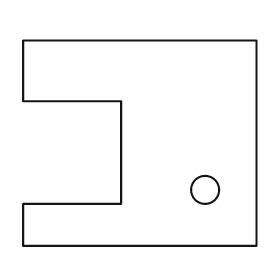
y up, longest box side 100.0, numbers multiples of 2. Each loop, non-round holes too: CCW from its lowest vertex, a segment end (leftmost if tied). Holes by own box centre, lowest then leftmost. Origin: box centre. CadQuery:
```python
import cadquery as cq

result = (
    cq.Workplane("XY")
    .moveTo(-50.0, -44.0)
    .lineTo(50.0, -44.0)
    .lineTo(50.0, 44.0)
    .lineTo(-50.0, 44.0)
    .lineTo(-50.0, 18.0)
    .lineTo(-8.0, 18.0)
    .lineTo(-8.0, -26.0)
    .lineTo(-50.0, -26.0)
    .close()
    .moveTo(28.0, -20.0)
    .circle(6.0)
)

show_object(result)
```